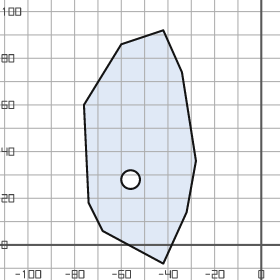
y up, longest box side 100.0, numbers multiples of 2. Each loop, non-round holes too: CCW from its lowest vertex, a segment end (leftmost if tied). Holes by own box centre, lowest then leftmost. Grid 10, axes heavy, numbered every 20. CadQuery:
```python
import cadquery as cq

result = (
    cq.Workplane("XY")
    .moveTo(-42.0, -8.0)
    .lineTo(-32.0, 14.0)
    .lineTo(-28.0, 36.0)
    .lineTo(-34.0, 74.0)
    .lineTo(-42.0, 92.0)
    .lineTo(-60.0, 86.0)
    .lineTo(-76.0, 60.0)
    .lineTo(-74.0, 18.0)
    .lineTo(-68.0, 6.0)
    .close()
    .moveTo(-56.0, 28.0)
    .circle(4.0)
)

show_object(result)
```